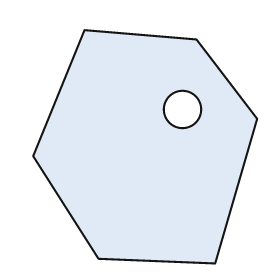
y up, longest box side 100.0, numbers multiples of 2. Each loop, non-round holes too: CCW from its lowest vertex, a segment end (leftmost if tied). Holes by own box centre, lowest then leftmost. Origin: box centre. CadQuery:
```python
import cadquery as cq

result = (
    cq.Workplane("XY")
    .moveTo(30.0, -50.0)
    .lineTo(48.0, 12.0)
    .lineTo(22.0, 46.0)
    .lineTo(-26.0, 50.0)
    .lineTo(-48.0, -4.0)
    .lineTo(-20.0, -48.0)
    .close()
    .moveTo(16.0, 16.0)
    .circle(8.0)
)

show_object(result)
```